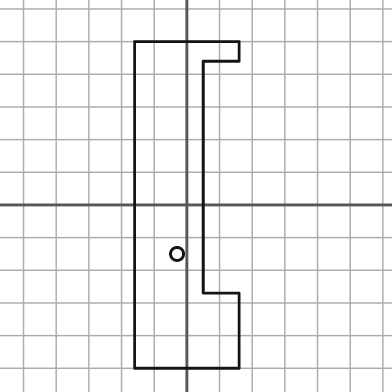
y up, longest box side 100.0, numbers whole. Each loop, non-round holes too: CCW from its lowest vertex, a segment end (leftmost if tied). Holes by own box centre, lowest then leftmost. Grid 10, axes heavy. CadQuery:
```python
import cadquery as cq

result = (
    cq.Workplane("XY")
    .moveTo(-16.0, -50.0)
    .lineTo(16.0, -50.0)
    .lineTo(16.0, -27.0)
    .lineTo(5.0, -27.0)
    .lineTo(5.0, 44.0)
    .lineTo(16.0, 44.0)
    .lineTo(16.0, 50.0)
    .lineTo(-16.0, 50.0)
    .close()
    .moveTo(-3.0, -15.0)
    .circle(2.0)
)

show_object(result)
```